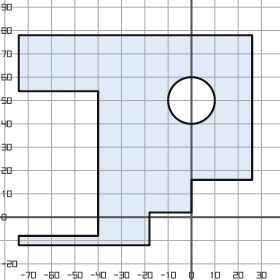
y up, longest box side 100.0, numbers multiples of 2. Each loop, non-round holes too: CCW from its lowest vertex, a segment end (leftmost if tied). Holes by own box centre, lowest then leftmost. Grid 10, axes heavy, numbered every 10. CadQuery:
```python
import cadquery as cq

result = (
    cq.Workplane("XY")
    .moveTo(-74.0, -12.0)
    .lineTo(-18.0, -12.0)
    .lineTo(-18.0, 2.0)
    .lineTo(0.0, 2.0)
    .lineTo(0.0, 16.0)
    .lineTo(26.0, 16.0)
    .lineTo(26.0, 78.0)
    .lineTo(-74.0, 78.0)
    .lineTo(-74.0, 54.0)
    .lineTo(-40.0, 54.0)
    .lineTo(-40.0, -8.0)
    .lineTo(-74.0, -8.0)
    .close()
    .moveTo(0.0, 50.0)
    .circle(10.0)
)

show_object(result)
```